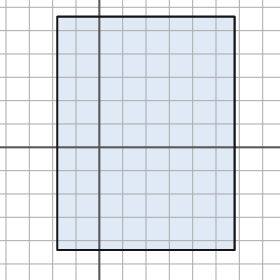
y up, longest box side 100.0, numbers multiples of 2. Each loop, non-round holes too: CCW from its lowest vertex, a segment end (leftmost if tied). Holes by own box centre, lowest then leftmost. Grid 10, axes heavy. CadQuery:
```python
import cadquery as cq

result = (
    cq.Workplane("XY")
    .moveTo(-18.0, -44.0)
    .lineTo(58.0, -44.0)
    .lineTo(58.0, 56.0)
    .lineTo(-18.0, 56.0)
    .close()
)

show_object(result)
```